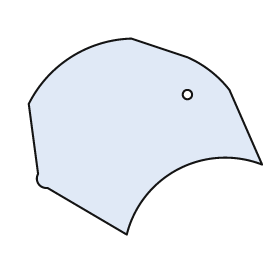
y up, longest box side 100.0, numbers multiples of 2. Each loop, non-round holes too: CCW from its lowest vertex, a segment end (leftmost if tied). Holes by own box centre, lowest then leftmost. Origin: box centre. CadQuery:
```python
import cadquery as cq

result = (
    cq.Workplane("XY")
    .moveTo(-8.0, -42.0)
    .threePointArc((14.0, -14.0), (50.0, -12.0))
    .lineTo(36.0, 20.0)
    .threePointArc((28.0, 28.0), (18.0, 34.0))
    .lineTo(-6.0, 42.0)
    .threePointArc((-32.0, 34.0), (-50.0, 14.0))
    .lineTo(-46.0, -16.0)
    .threePointArc((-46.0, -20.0), (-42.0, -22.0))
    .close()
    .moveTo(18.0, 18.0)
    .circle(2.0)
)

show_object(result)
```